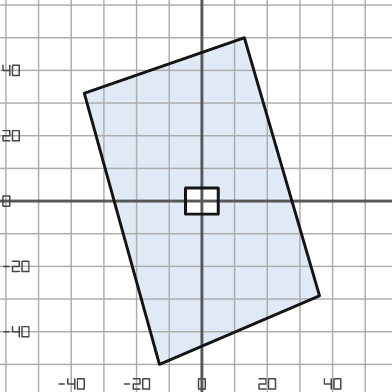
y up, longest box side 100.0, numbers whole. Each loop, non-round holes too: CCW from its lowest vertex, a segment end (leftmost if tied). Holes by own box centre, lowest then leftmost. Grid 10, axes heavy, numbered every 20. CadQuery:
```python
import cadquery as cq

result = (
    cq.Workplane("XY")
    .moveTo(-13.0, -50.0)
    .lineTo(36.0, -29.0)
    .lineTo(13.0, 50.0)
    .lineTo(-36.0, 33.0)
    .close()
    .moveTo(-5.0, -4.0)
    .lineTo(5.0, -4.0)
    .lineTo(5.0, 4.0)
    .lineTo(-5.0, 4.0)
    .close()
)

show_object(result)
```